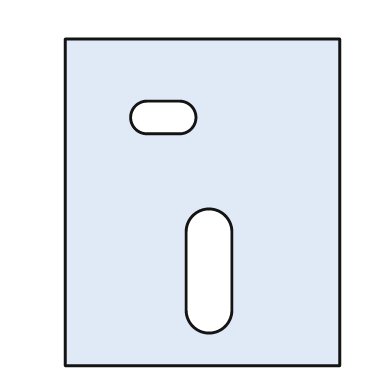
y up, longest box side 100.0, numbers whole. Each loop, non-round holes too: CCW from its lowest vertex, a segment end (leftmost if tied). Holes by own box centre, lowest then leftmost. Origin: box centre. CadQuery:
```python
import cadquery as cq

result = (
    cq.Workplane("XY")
    .moveTo(-42.0, -50.0)
    .lineTo(42.0, -50.0)
    .lineTo(42.0, 50.0)
    .lineTo(-42.0, 50.0)
    .close()
    .moveTo(-5.0, -33.0)
    .threePointArc((2.0, -40.0), (9.0, -33.0))
    .lineTo(9.0, -9.0)
    .threePointArc((2.0, -2.0), (-5.0, -9.0))
    .close()
    .moveTo(-17.0, 21.0)
    .lineTo(-7.0, 21.0)
    .threePointArc((-2.0, 26.0), (-7.0, 31.0))
    .lineTo(-17.0, 31.0)
    .threePointArc((-22.0, 26.0), (-17.0, 21.0))
    .close()
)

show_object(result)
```